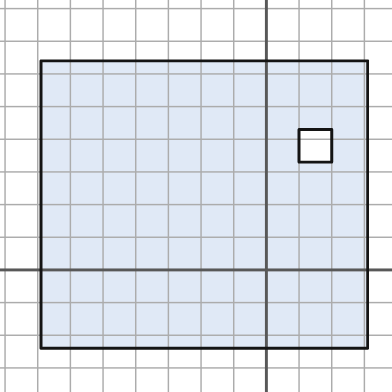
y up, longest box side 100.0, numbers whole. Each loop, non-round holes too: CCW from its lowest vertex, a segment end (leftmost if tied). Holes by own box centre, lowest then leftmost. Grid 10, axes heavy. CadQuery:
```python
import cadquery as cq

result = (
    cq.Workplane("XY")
    .moveTo(-69.0, -24.0)
    .lineTo(31.0, -24.0)
    .lineTo(31.0, 64.0)
    .lineTo(-69.0, 64.0)
    .close()
    .moveTo(10.0, 33.0)
    .lineTo(20.0, 33.0)
    .lineTo(20.0, 43.0)
    .lineTo(10.0, 43.0)
    .close()
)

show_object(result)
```